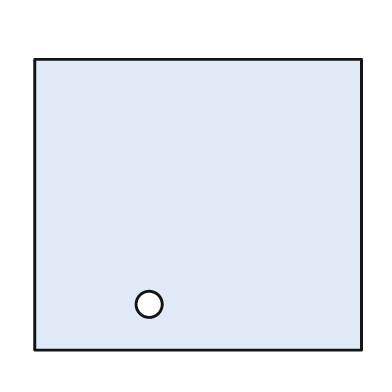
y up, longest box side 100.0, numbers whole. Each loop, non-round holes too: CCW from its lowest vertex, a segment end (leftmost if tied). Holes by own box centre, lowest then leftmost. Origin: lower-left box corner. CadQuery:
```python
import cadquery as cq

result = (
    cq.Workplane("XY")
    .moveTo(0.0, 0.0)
    .lineTo(100.0, 0.0)
    .lineTo(100.0, 89.0)
    .lineTo(0.0, 89.0)
    .close()
    .moveTo(35.0, 14.0)
    .circle(4.0)
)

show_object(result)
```